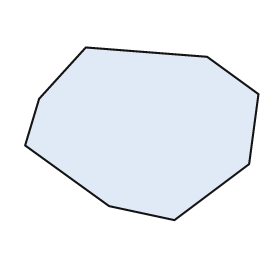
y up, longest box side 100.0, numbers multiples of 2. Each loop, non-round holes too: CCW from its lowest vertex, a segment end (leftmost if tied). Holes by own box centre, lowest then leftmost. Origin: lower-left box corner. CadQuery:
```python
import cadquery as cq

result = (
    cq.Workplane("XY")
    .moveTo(64.0, 0.0)
    .lineTo(96.0, 24.0)
    .lineTo(100.0, 54.0)
    .lineTo(78.0, 70.0)
    .lineTo(26.0, 74.0)
    .lineTo(6.0, 52.0)
    .lineTo(0.0, 32.0)
    .lineTo(36.0, 6.0)
    .close()
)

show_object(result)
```